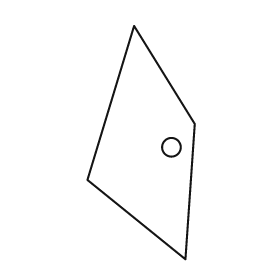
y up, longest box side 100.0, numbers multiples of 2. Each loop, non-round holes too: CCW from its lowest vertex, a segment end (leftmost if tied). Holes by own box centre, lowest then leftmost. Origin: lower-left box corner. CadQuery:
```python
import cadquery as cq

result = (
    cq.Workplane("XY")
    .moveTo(42.0, 0.0)
    .lineTo(46.0, 58.0)
    .lineTo(20.0, 100.0)
    .lineTo(0.0, 34.0)
    .close()
    .moveTo(36.0, 48.0)
    .circle(4.0)
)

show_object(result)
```